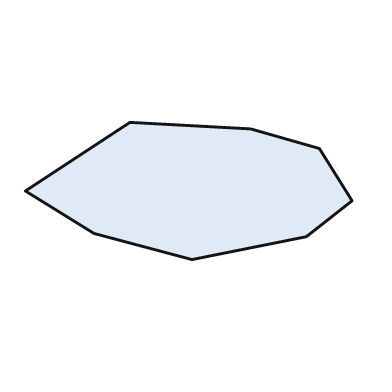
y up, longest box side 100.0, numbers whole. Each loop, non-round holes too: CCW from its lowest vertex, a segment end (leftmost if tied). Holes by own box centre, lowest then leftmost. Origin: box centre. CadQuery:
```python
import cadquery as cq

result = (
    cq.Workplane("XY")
    .moveTo(1.0, -21.0)
    .lineTo(36.0, -14.0)
    .lineTo(50.0, -3.0)
    .lineTo(40.0, 13.0)
    .lineTo(19.0, 19.0)
    .lineTo(-18.0, 21.0)
    .lineTo(-50.0, 0.0)
    .lineTo(-29.0, -13.0)
    .close()
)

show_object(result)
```